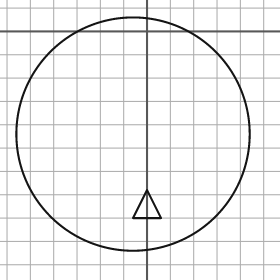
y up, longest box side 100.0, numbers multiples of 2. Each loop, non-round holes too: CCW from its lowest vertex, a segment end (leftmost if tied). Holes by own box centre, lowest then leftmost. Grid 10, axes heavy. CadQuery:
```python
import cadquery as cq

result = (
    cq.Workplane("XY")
    .moveTo(-6.0, -44.0)
    .circle(50.0)
    .moveTo(-6.0, -80.0)
    .lineTo(6.0, -80.0)
    .lineTo(0.0, -68.0)
    .close()
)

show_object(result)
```